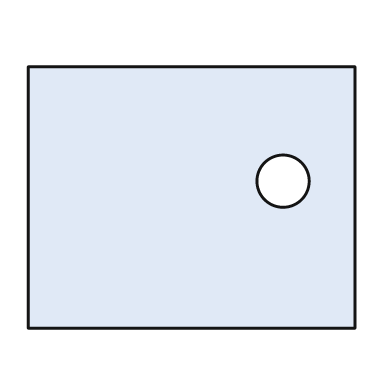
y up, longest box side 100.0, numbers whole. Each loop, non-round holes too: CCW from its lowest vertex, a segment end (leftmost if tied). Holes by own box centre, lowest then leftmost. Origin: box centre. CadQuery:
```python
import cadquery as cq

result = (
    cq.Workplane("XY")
    .moveTo(-50.0, -40.0)
    .lineTo(50.0, -40.0)
    .lineTo(50.0, 40.0)
    .lineTo(-50.0, 40.0)
    .close()
    .moveTo(28.0, 5.0)
    .circle(8.0)
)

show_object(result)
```